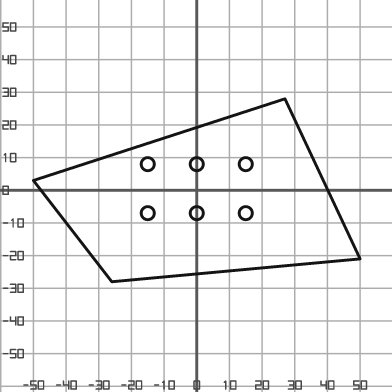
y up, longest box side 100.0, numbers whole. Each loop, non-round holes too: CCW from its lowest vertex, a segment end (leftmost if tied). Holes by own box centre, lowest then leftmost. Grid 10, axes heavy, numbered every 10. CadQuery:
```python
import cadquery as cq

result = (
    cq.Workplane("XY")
    .moveTo(-26.0, -28.0)
    .lineTo(50.0, -21.0)
    .lineTo(27.0, 28.0)
    .lineTo(-50.0, 3.0)
    .close()
    .moveTo(-15.0, -7.0)
    .circle(2.0)
    .moveTo(0.0, -7.0)
    .circle(2.0)
    .moveTo(15.0, -7.0)
    .circle(2.0)
    .moveTo(-15.0, 8.0)
    .circle(2.0)
    .moveTo(0.0, 8.0)
    .circle(2.0)
    .moveTo(15.0, 8.0)
    .circle(2.0)
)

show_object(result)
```